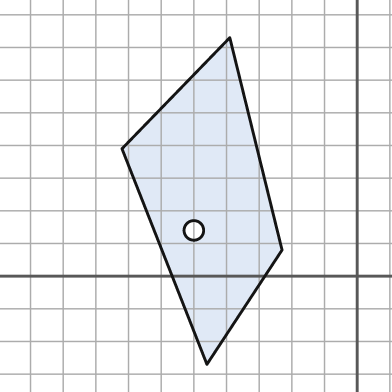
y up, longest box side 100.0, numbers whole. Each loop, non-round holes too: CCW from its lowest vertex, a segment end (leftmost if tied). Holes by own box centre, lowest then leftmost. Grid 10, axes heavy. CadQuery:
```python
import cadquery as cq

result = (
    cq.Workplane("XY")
    .moveTo(-46.0, -27.0)
    .lineTo(-23.0, 8.0)
    .lineTo(-39.0, 73.0)
    .lineTo(-72.0, 39.0)
    .close()
    .moveTo(-50.0, 14.0)
    .circle(3.0)
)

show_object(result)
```